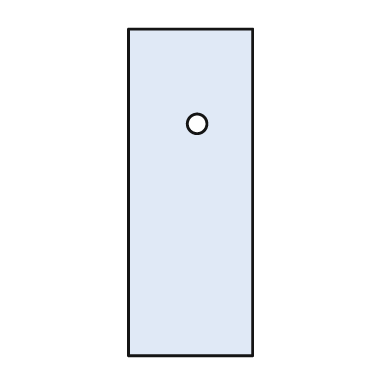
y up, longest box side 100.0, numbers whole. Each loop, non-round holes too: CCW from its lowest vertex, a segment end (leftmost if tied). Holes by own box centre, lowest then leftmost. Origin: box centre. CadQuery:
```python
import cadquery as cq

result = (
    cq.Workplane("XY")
    .moveTo(-19.0, -50.0)
    .lineTo(19.0, -50.0)
    .lineTo(19.0, 50.0)
    .lineTo(-19.0, 50.0)
    .close()
    .moveTo(2.0, 21.0)
    .circle(3.0)
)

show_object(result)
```